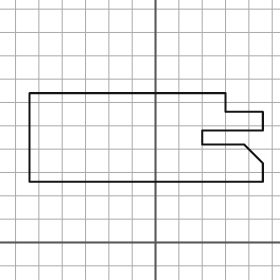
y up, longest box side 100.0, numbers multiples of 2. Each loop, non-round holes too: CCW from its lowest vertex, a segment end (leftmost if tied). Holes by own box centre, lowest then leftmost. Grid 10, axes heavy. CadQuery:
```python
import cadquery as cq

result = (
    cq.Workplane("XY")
    .moveTo(-54.0, 26.0)
    .lineTo(46.0, 26.0)
    .lineTo(46.0, 34.0)
    .lineTo(38.0, 42.0)
    .lineTo(20.0, 42.0)
    .lineTo(20.0, 48.0)
    .lineTo(46.0, 48.0)
    .lineTo(46.0, 56.0)
    .lineTo(30.0, 56.0)
    .lineTo(30.0, 64.0)
    .lineTo(-54.0, 64.0)
    .close()
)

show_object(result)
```